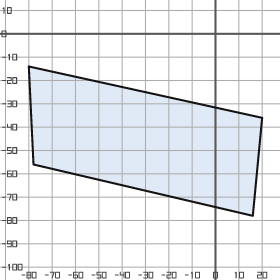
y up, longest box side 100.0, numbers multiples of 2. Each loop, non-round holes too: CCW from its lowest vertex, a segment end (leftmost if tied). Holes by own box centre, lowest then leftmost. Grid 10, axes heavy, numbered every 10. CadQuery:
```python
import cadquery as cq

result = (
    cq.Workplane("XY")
    .moveTo(16.0, -78.0)
    .lineTo(20.0, -36.0)
    .lineTo(-80.0, -14.0)
    .lineTo(-78.0, -56.0)
    .close()
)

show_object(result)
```